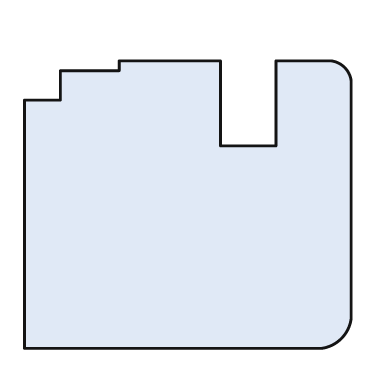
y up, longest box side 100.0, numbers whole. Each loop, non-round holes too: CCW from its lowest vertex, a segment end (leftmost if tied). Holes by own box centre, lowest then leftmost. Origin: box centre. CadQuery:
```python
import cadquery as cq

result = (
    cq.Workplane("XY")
    .moveTo(-50.0, -44.0)
    .lineTo(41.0, -44.0)
    .threePointArc((47.0, -41.0), (50.0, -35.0))
    .lineTo(50.0, 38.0)
    .threePointArc((48.0, 42.0), (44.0, 44.0))
    .lineTo(27.0, 44.0)
    .lineTo(27.0, 18.0)
    .lineTo(10.0, 18.0)
    .lineTo(10.0, 44.0)
    .lineTo(-21.0, 44.0)
    .lineTo(-21.0, 41.0)
    .lineTo(-39.0, 41.0)
    .lineTo(-39.0, 32.0)
    .lineTo(-50.0, 32.0)
    .close()
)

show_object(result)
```